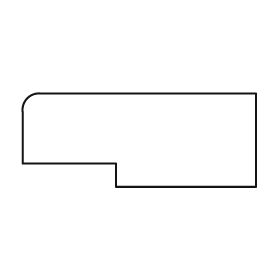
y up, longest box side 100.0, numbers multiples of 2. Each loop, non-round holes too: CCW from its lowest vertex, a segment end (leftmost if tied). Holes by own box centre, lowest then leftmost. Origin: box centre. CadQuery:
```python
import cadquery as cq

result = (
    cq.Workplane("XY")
    .moveTo(-10.0, -20.0)
    .lineTo(50.0, -20.0)
    .lineTo(50.0, 20.0)
    .lineTo(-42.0, 20.0)
    .threePointArc((-48.0, 18.0), (-50.0, 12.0))
    .lineTo(-50.0, -10.0)
    .lineTo(-10.0, -10.0)
    .close()
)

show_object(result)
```